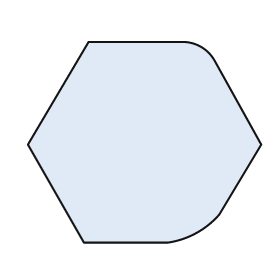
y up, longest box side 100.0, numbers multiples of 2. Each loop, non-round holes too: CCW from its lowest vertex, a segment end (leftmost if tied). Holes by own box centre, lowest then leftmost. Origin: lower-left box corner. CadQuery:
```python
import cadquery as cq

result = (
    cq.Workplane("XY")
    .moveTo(24.0, 0.0)
    .lineTo(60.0, 0.0)
    .threePointArc((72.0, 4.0), (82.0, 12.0))
    .lineTo(100.0, 42.0)
    .lineTo(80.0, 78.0)
    .threePointArc((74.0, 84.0), (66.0, 86.0))
    .lineTo(26.0, 86.0)
    .lineTo(0.0, 42.0)
    .close()
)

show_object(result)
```